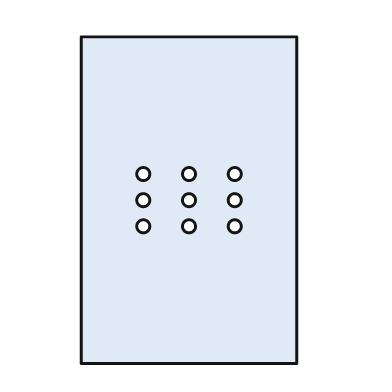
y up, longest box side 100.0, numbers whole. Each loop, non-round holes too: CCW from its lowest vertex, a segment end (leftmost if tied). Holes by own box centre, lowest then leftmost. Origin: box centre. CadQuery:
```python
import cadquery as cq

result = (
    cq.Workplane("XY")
    .moveTo(-33.0, -50.0)
    .lineTo(33.0, -50.0)
    .lineTo(33.0, 50.0)
    .lineTo(-33.0, 50.0)
    .close()
    .moveTo(-14.0, -8.0)
    .circle(2.0)
    .moveTo(0.0, -8.0)
    .circle(2.0)
    .moveTo(14.0, -8.0)
    .circle(2.0)
    .moveTo(-14.0, 0.0)
    .circle(2.0)
    .moveTo(0.0, 0.0)
    .circle(2.0)
    .moveTo(14.0, 0.0)
    .circle(2.0)
    .moveTo(-14.0, 8.0)
    .circle(2.0)
    .moveTo(0.0, 8.0)
    .circle(2.0)
    .moveTo(14.0, 8.0)
    .circle(2.0)
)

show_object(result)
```